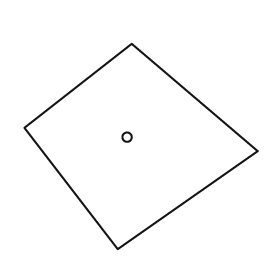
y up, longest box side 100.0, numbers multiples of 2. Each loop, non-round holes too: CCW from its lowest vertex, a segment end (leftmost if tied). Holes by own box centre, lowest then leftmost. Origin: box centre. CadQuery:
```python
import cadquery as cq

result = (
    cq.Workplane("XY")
    .moveTo(-10.0, -44.0)
    .lineTo(50.0, -2.0)
    .lineTo(-4.0, 44.0)
    .lineTo(-50.0, 8.0)
    .close()
    .moveTo(-6.0, 4.0)
    .circle(2.0)
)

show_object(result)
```